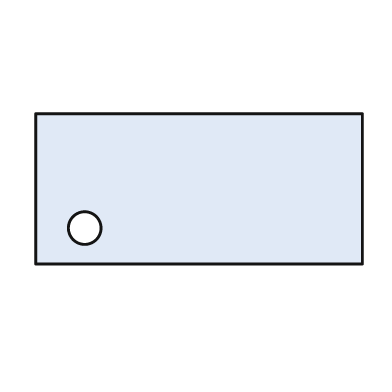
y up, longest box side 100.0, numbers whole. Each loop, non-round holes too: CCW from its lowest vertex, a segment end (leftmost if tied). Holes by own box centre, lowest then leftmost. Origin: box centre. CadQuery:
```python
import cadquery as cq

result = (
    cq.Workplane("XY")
    .moveTo(-50.0, -23.0)
    .lineTo(50.0, -23.0)
    .lineTo(50.0, 23.0)
    .lineTo(-50.0, 23.0)
    .close()
    .moveTo(-35.0, -12.0)
    .circle(5.0)
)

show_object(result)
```